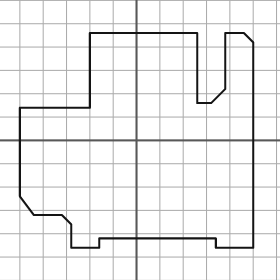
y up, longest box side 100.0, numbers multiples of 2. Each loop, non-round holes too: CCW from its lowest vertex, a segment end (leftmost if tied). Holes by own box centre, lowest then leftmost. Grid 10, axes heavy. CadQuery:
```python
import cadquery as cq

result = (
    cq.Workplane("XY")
    .moveTo(-28.0, -46.0)
    .lineTo(-16.0, -46.0)
    .lineTo(-16.0, -42.0)
    .lineTo(34.0, -42.0)
    .lineTo(34.0, -46.0)
    .lineTo(50.0, -46.0)
    .lineTo(50.0, 42.0)
    .lineTo(46.0, 46.0)
    .lineTo(38.0, 46.0)
    .lineTo(38.0, 22.0)
    .lineTo(32.0, 16.0)
    .lineTo(26.0, 16.0)
    .lineTo(26.0, 46.0)
    .lineTo(-20.0, 46.0)
    .lineTo(-20.0, 14.0)
    .lineTo(-50.0, 14.0)
    .lineTo(-50.0, -24.0)
    .lineTo(-44.0, -32.0)
    .lineTo(-32.0, -32.0)
    .lineTo(-28.0, -36.0)
    .close()
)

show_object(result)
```